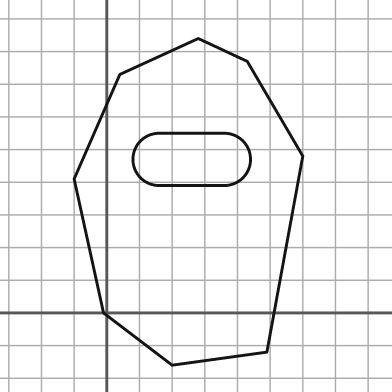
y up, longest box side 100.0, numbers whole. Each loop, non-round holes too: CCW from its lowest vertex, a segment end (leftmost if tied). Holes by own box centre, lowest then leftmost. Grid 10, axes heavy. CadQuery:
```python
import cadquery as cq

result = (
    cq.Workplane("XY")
    .moveTo(20.0, -16.0)
    .lineTo(49.0, -12.0)
    .lineTo(60.0, 48.0)
    .lineTo(43.0, 77.0)
    .lineTo(28.0, 84.0)
    .lineTo(4.0, 73.0)
    .lineTo(-10.0, 41.0)
    .lineTo(-1.0, 0.0)
    .close()
    .moveTo(16.0, 39.0)
    .lineTo(36.0, 39.0)
    .threePointArc((44.0, 47.0), (36.0, 55.0))
    .lineTo(16.0, 55.0)
    .threePointArc((8.0, 47.0), (16.0, 39.0))
    .close()
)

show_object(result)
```